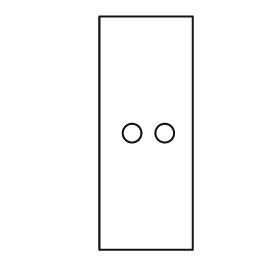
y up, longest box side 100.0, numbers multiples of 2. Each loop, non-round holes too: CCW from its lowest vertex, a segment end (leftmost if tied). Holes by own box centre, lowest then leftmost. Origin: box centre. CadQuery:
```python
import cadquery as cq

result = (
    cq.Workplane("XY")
    .moveTo(-20.0, -50.0)
    .lineTo(20.0, -50.0)
    .lineTo(20.0, 50.0)
    .lineTo(-20.0, 50.0)
    .close()
    .moveTo(-6.0, 0.0)
    .circle(4.0)
    .moveTo(8.0, 0.0)
    .circle(4.0)
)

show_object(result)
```